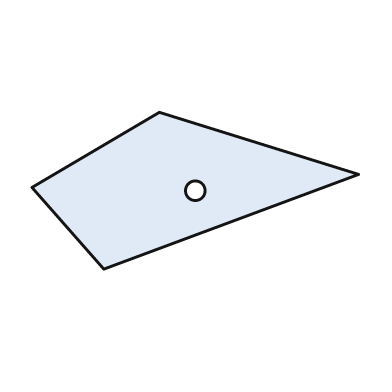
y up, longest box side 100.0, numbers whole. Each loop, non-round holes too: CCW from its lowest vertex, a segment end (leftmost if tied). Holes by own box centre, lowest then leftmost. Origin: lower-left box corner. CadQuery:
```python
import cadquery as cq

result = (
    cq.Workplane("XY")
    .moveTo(22.0, 0.0)
    .lineTo(100.0, 29.0)
    .lineTo(39.0, 48.0)
    .lineTo(0.0, 25.0)
    .close()
    .moveTo(50.0, 24.0)
    .circle(3.0)
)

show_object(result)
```